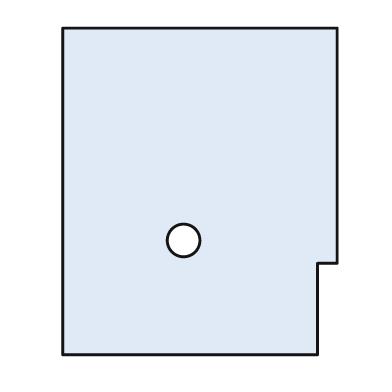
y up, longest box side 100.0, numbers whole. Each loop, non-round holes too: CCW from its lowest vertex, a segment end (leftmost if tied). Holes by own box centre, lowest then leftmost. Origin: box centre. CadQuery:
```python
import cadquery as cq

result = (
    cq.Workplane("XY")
    .moveTo(-42.0, -50.0)
    .lineTo(36.0, -50.0)
    .lineTo(36.0, -22.0)
    .lineTo(42.0, -22.0)
    .lineTo(42.0, 50.0)
    .lineTo(-42.0, 50.0)
    .close()
    .moveTo(-5.0, -15.0)
    .circle(5.0)
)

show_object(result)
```